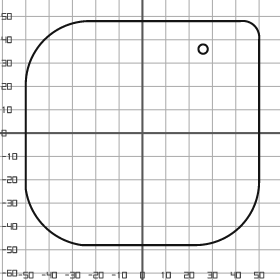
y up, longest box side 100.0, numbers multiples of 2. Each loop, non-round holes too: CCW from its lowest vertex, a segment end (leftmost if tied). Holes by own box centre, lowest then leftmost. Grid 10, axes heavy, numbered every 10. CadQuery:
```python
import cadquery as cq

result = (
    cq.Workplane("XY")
    .moveTo(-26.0, -48.0)
    .lineTo(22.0, -48.0)
    .threePointArc((42.0, -40.0), (50.0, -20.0))
    .lineTo(50.0, 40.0)
    .threePointArc((48.0, 46.0), (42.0, 48.0))
    .lineTo(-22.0, 48.0)
    .threePointArc((-42.0, 40.0), (-50.0, 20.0))
    .lineTo(-50.0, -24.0)
    .threePointArc((-42.0, -40.0), (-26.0, -48.0))
    .close()
    .moveTo(26.0, 36.0)
    .circle(2.0)
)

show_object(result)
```